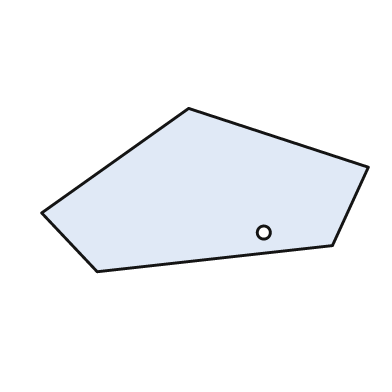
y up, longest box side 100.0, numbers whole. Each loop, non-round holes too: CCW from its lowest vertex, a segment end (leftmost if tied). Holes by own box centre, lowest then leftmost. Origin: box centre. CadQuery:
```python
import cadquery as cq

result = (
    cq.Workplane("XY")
    .moveTo(-33.0, -25.0)
    .lineTo(39.0, -17.0)
    .lineTo(50.0, 7.0)
    .lineTo(-5.0, 25.0)
    .lineTo(-50.0, -7.0)
    .close()
    .moveTo(18.0, -13.0)
    .circle(2.0)
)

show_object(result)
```